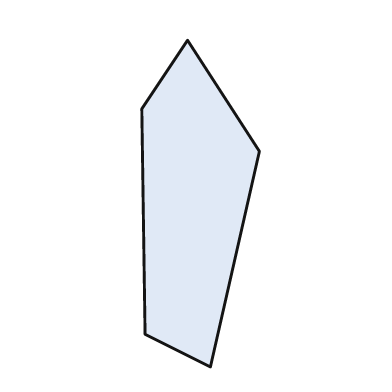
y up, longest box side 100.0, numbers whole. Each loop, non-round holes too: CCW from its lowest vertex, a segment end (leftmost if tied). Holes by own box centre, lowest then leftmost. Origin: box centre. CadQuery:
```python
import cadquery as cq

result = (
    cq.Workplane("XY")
    .moveTo(3.0, -50.0)
    .lineTo(18.0, 16.0)
    .lineTo(-4.0, 50.0)
    .lineTo(-18.0, 29.0)
    .lineTo(-17.0, -40.0)
    .close()
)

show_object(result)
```